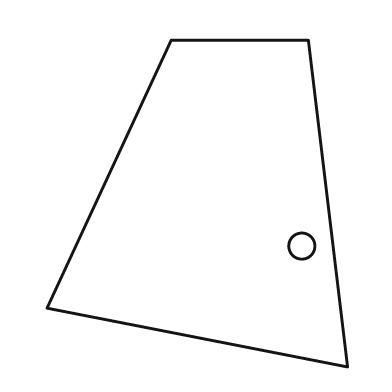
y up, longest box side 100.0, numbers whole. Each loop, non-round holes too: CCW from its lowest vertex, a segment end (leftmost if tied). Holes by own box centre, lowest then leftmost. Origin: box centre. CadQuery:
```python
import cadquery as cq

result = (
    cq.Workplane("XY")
    .moveTo(46.0, -50.0)
    .lineTo(34.0, 50.0)
    .lineTo(-8.0, 50.0)
    .lineTo(-46.0, -32.0)
    .close()
    .moveTo(32.0, -13.0)
    .circle(4.0)
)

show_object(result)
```